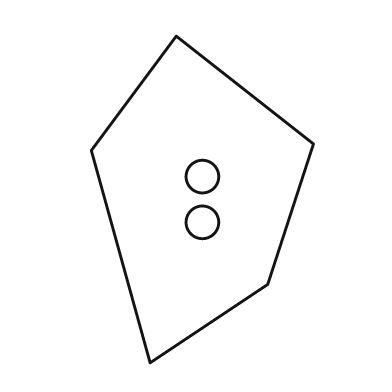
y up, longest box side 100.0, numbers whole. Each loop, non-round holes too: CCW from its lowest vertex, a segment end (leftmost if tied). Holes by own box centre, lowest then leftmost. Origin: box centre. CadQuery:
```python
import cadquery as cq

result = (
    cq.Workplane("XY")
    .moveTo(-16.0, -50.0)
    .lineTo(20.0, -26.0)
    .lineTo(34.0, 17.0)
    .lineTo(-8.0, 50.0)
    .lineTo(-34.0, 15.0)
    .close()
    .moveTo(0.0, -7.0)
    .circle(5.0)
    .moveTo(0.0, 7.0)
    .circle(5.0)
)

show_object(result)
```